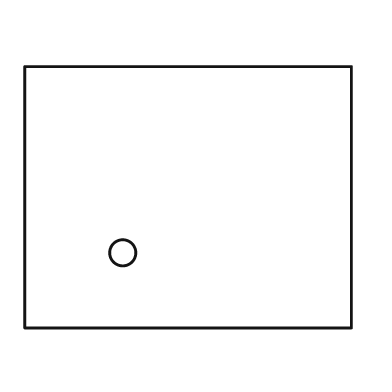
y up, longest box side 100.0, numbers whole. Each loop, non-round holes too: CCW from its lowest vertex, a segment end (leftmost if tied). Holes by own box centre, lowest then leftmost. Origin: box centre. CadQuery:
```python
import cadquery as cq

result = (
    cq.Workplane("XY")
    .moveTo(-50.0, -40.0)
    .lineTo(50.0, -40.0)
    .lineTo(50.0, 40.0)
    .lineTo(-50.0, 40.0)
    .close()
    .moveTo(-20.0, -17.0)
    .circle(4.0)
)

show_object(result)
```